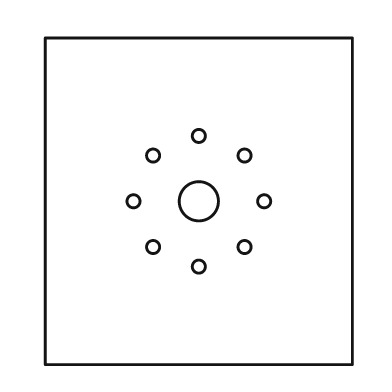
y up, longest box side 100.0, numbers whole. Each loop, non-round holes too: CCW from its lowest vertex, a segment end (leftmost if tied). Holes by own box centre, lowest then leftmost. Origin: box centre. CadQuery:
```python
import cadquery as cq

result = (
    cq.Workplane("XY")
    .moveTo(-47.0, -50.0)
    .lineTo(47.0, -50.0)
    .lineTo(47.0, 50.0)
    .lineTo(-47.0, 50.0)
    .close()
    .moveTo(0.0, -20.0)
    .circle(2.0)
    .moveTo(-14.0, -14.0)
    .circle(2.0)
    .moveTo(14.0, -14.0)
    .circle(2.0)
    .moveTo(-20.0, 0.0)
    .circle(2.0)
    .moveTo(0.0, 0.0)
    .circle(6.0)
    .moveTo(20.0, 0.0)
    .circle(2.0)
    .moveTo(-14.0, 14.0)
    .circle(2.0)
    .moveTo(14.0, 14.0)
    .circle(2.0)
    .moveTo(0.0, 20.0)
    .circle(2.0)
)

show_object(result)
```